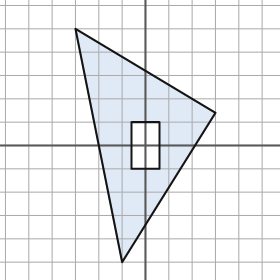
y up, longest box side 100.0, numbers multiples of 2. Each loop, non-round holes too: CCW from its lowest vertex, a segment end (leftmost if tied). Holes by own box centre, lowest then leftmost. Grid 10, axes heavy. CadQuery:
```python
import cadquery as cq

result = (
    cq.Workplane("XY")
    .moveTo(-10.0, -50.0)
    .lineTo(30.0, 14.0)
    .lineTo(-30.0, 50.0)
    .close()
    .moveTo(-6.0, -10.0)
    .lineTo(6.0, -10.0)
    .lineTo(6.0, 10.0)
    .lineTo(-6.0, 10.0)
    .close()
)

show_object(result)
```